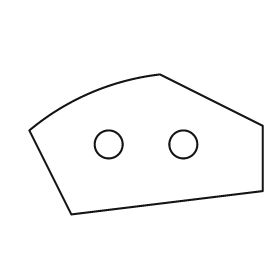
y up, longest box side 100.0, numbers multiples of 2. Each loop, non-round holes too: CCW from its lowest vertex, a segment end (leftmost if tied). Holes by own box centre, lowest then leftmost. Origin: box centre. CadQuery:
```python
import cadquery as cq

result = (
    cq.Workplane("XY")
    .moveTo(-32.0, -30.0)
    .lineTo(50.0, -20.0)
    .lineTo(50.0, 8.0)
    .lineTo(6.0, 30.0)
    .threePointArc((-24.0, 22.0), (-50.0, 6.0))
    .close()
    .moveTo(-16.0, 0.0)
    .circle(6.0)
    .moveTo(16.0, 0.0)
    .circle(6.0)
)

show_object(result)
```